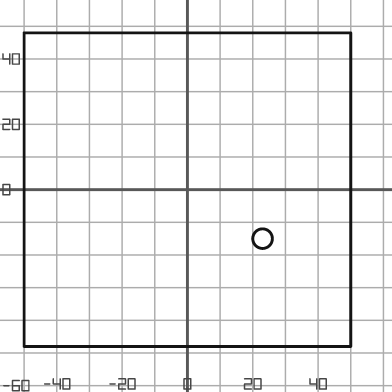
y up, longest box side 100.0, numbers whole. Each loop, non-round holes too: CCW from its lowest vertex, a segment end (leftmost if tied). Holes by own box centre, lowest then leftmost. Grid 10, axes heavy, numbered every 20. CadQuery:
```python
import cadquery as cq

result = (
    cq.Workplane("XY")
    .moveTo(-50.0, -48.0)
    .lineTo(50.0, -48.0)
    .lineTo(50.0, 48.0)
    .lineTo(-50.0, 48.0)
    .close()
    .moveTo(23.0, -15.0)
    .circle(3.0)
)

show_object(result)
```